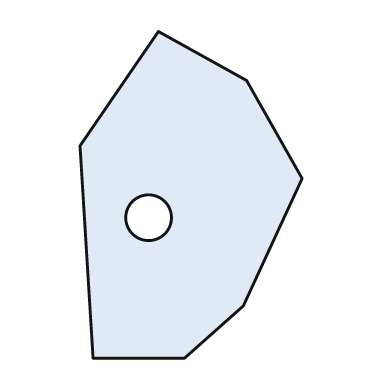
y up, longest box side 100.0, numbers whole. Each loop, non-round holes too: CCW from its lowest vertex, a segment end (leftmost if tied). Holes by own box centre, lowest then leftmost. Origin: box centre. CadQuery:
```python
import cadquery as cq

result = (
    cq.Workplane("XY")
    .moveTo(-30.0, -50.0)
    .lineTo(-2.0, -50.0)
    .lineTo(16.0, -34.0)
    .lineTo(34.0, 5.0)
    .lineTo(17.0, 35.0)
    .lineTo(-10.0, 50.0)
    .lineTo(-34.0, 15.0)
    .close()
    .moveTo(-13.0, -7.0)
    .circle(7.0)
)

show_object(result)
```